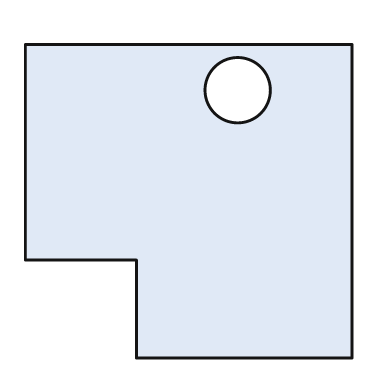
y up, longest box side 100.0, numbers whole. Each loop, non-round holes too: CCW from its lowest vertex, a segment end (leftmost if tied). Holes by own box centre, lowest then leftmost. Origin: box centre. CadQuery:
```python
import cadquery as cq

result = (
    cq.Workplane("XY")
    .moveTo(-16.0, -48.0)
    .lineTo(50.0, -48.0)
    .lineTo(50.0, 48.0)
    .lineTo(-50.0, 48.0)
    .lineTo(-50.0, -18.0)
    .lineTo(-16.0, -18.0)
    .close()
    .moveTo(15.0, 34.0)
    .circle(10.0)
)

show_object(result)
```